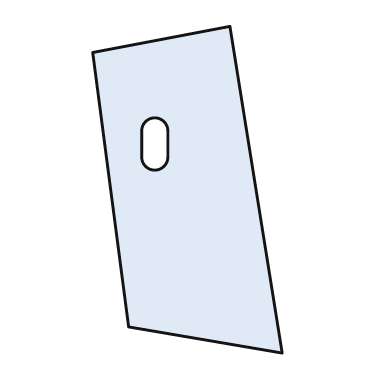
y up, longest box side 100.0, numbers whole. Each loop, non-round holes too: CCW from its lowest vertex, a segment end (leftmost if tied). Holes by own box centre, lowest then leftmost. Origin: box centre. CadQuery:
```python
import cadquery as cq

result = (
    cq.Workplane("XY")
    .moveTo(29.0, -50.0)
    .lineTo(13.0, 50.0)
    .lineTo(-29.0, 42.0)
    .lineTo(-18.0, -42.0)
    .close()
    .moveTo(-14.0, 10.0)
    .threePointArc((-10.0, 6.0), (-6.0, 10.0))
    .lineTo(-6.0, 18.0)
    .threePointArc((-10.0, 22.0), (-14.0, 18.0))
    .close()
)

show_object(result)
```